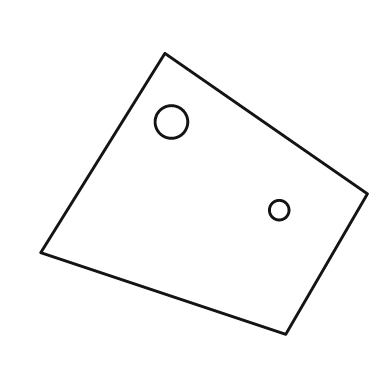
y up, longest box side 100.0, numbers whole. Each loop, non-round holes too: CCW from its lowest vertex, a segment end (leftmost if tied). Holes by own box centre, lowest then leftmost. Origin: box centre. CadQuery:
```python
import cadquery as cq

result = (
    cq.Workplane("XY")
    .moveTo(25.0, -43.0)
    .lineTo(50.0, 0.0)
    .lineTo(-12.0, 43.0)
    .lineTo(-50.0, -18.0)
    .close()
    .moveTo(23.0, -5.0)
    .circle(3.0)
    .moveTo(-10.0, 22.0)
    .circle(5.0)
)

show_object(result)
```